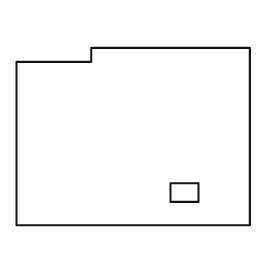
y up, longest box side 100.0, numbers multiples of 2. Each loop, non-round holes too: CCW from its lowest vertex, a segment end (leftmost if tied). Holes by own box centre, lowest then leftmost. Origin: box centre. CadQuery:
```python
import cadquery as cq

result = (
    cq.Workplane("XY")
    .moveTo(-50.0, -38.0)
    .lineTo(50.0, -38.0)
    .lineTo(50.0, 38.0)
    .lineTo(-18.0, 38.0)
    .lineTo(-18.0, 32.0)
    .lineTo(-50.0, 32.0)
    .close()
    .moveTo(16.0, -28.0)
    .lineTo(28.0, -28.0)
    .lineTo(28.0, -20.0)
    .lineTo(16.0, -20.0)
    .close()
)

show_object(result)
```